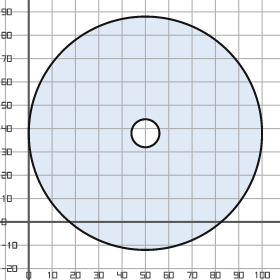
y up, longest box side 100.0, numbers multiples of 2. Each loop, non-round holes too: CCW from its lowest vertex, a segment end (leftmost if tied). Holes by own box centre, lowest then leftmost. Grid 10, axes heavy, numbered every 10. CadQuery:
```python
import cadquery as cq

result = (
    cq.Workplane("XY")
    .moveTo(50.0, 38.0)
    .circle(50.0)
    .moveTo(50.0, 38.0)
    .circle(6.0)
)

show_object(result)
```